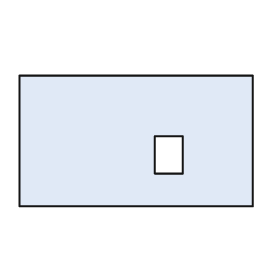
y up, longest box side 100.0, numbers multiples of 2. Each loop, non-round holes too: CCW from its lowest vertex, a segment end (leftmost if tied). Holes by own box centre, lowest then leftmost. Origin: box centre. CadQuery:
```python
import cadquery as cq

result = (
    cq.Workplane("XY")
    .moveTo(-50.0, -28.0)
    .lineTo(50.0, -28.0)
    .lineTo(50.0, 28.0)
    .lineTo(-50.0, 28.0)
    .close()
    .moveTo(8.0, -14.0)
    .lineTo(20.0, -14.0)
    .lineTo(20.0, 2.0)
    .lineTo(8.0, 2.0)
    .close()
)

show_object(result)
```